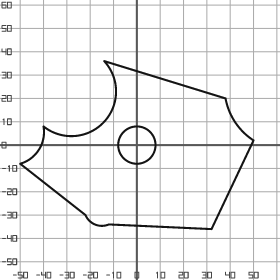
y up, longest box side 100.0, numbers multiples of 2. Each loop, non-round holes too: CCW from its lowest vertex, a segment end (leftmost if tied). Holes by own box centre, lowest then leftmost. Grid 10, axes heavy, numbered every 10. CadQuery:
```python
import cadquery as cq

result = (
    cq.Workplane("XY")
    .moveTo(32.0, -36.0)
    .lineTo(50.0, 2.0)
    .threePointArc((42.0, 10.0), (38.0, 20.0))
    .lineTo(-14.0, 36.0)
    .threePointArc((-14.0, 10.0), (-40.0, 8.0))
    .threePointArc((-42.0, -2.0), (-50.0, -8.0))
    .lineTo(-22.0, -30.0)
    .threePointArc((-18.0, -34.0), (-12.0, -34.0))
    .close()
    .moveTo(0.0, 0.0)
    .circle(8.0)
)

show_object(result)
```